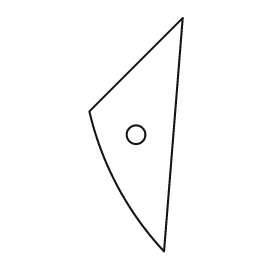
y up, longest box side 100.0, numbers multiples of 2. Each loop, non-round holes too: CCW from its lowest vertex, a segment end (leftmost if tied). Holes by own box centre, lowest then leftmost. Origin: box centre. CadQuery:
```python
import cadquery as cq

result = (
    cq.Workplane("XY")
    .moveTo(12.0, -50.0)
    .lineTo(20.0, 50.0)
    .lineTo(-20.0, 10.0)
    .threePointArc((-8.0, -22.0), (12.0, -50.0))
    .close()
    .moveTo(0.0, 0.0)
    .circle(4.0)
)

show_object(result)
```